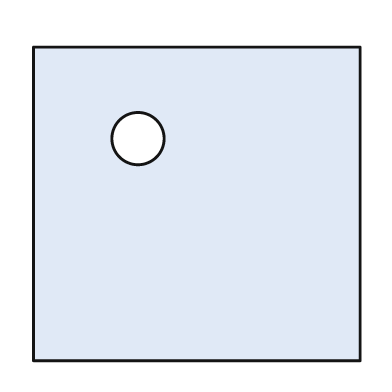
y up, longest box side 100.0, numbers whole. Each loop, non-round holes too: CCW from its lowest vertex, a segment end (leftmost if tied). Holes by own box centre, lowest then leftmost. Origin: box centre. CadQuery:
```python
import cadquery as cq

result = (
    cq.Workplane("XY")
    .moveTo(-50.0, -48.0)
    .lineTo(50.0, -48.0)
    .lineTo(50.0, 48.0)
    .lineTo(-50.0, 48.0)
    .close()
    .moveTo(-18.0, 20.0)
    .circle(8.0)
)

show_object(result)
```